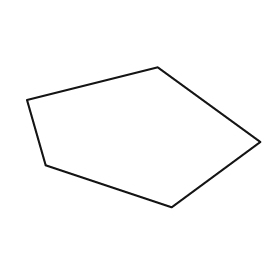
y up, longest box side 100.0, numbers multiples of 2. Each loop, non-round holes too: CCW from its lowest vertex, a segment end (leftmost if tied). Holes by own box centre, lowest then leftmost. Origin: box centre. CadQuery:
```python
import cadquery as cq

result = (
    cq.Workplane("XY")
    .moveTo(12.0, -30.0)
    .lineTo(50.0, -2.0)
    .lineTo(6.0, 30.0)
    .lineTo(-50.0, 16.0)
    .lineTo(-42.0, -12.0)
    .close()
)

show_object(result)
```